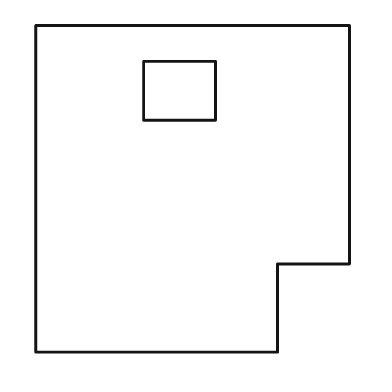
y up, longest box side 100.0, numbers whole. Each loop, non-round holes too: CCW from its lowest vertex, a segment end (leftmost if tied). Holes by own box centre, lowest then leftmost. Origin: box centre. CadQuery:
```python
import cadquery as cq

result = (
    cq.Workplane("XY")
    .moveTo(-48.0, -50.0)
    .lineTo(26.0, -50.0)
    .lineTo(26.0, -23.0)
    .lineTo(48.0, -23.0)
    .lineTo(48.0, 50.0)
    .lineTo(-48.0, 50.0)
    .close()
    .moveTo(-15.0, 21.0)
    .lineTo(7.0, 21.0)
    .lineTo(7.0, 39.0)
    .lineTo(-15.0, 39.0)
    .close()
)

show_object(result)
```